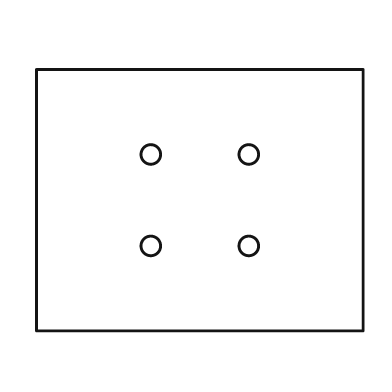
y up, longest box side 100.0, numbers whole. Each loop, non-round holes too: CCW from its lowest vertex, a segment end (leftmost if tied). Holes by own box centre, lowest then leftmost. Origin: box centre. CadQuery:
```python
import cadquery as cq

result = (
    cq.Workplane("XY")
    .moveTo(-50.0, -40.0)
    .lineTo(50.0, -40.0)
    .lineTo(50.0, 40.0)
    .lineTo(-50.0, 40.0)
    .close()
    .moveTo(-15.0, -14.0)
    .circle(3.0)
    .moveTo(15.0, -14.0)
    .circle(3.0)
    .moveTo(-15.0, 14.0)
    .circle(3.0)
    .moveTo(15.0, 14.0)
    .circle(3.0)
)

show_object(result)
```